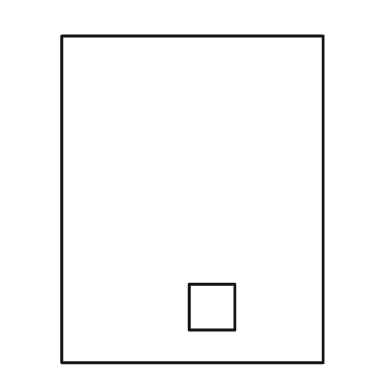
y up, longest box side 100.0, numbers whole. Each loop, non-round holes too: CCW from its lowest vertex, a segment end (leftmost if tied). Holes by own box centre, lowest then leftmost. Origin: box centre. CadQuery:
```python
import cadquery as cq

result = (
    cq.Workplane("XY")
    .moveTo(-40.0, -50.0)
    .lineTo(40.0, -50.0)
    .lineTo(40.0, 50.0)
    .lineTo(-40.0, 50.0)
    .close()
    .moveTo(-1.0, -40.0)
    .lineTo(13.0, -40.0)
    .lineTo(13.0, -26.0)
    .lineTo(-1.0, -26.0)
    .close()
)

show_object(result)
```